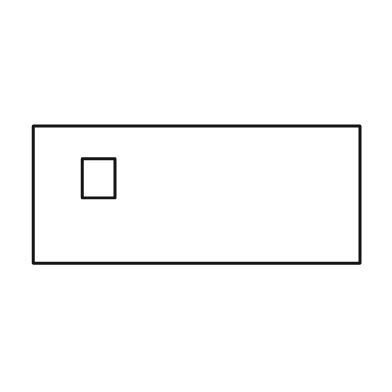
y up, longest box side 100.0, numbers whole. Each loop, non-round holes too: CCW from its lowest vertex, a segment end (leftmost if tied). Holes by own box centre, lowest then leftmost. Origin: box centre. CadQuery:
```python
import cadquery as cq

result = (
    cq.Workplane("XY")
    .moveTo(-50.0, -21.0)
    .lineTo(50.0, -21.0)
    .lineTo(50.0, 21.0)
    .lineTo(-50.0, 21.0)
    .close()
    .moveTo(-35.0, -1.0)
    .lineTo(-25.0, -1.0)
    .lineTo(-25.0, 11.0)
    .lineTo(-35.0, 11.0)
    .close()
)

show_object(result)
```